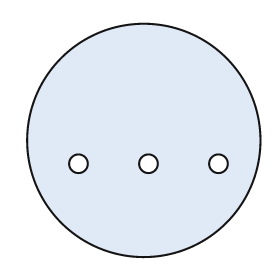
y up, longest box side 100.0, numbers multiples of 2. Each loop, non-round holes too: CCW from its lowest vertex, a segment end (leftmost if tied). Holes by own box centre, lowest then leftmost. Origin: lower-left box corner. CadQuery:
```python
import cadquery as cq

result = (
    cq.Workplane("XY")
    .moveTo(50.0, 50.0)
    .circle(50.0)
    .moveTo(22.0, 40.0)
    .circle(4.0)
    .moveTo(52.0, 40.0)
    .circle(4.0)
    .moveTo(82.0, 40.0)
    .circle(4.0)
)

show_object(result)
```